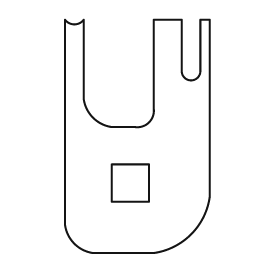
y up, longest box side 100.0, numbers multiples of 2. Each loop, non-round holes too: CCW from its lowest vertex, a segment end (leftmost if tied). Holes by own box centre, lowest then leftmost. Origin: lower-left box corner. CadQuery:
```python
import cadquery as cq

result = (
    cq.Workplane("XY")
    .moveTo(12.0, 0.0)
    .lineTo(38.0, 0.0)
    .threePointArc((54.0, 8.0), (62.0, 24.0))
    .lineTo(62.0, 100.0)
    .lineTo(58.0, 100.0)
    .lineTo(58.0, 78.0)
    .threePointArc((54.0, 74.0), (50.0, 78.0))
    .lineTo(50.0, 100.0)
    .lineTo(38.0, 100.0)
    .lineTo(38.0, 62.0)
    .threePointArc((36.0, 56.0), (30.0, 54.0))
    .lineTo(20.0, 54.0)
    .threePointArc((12.0, 58.0), (8.0, 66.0))
    .lineTo(8.0, 100.0)
    .threePointArc((4.0, 98.0), (0.0, 100.0))
    .lineTo(0.0, 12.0)
    .threePointArc((4.0, 4.0), (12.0, 0.0))
    .close()
    .moveTo(20.0, 22.0)
    .lineTo(36.0, 22.0)
    .lineTo(36.0, 38.0)
    .lineTo(20.0, 38.0)
    .close()
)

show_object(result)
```